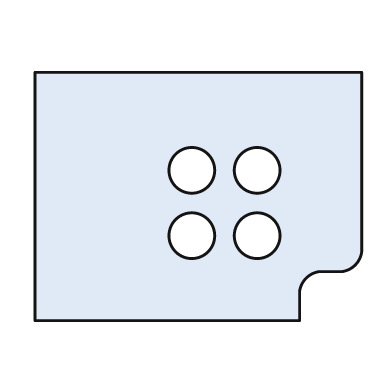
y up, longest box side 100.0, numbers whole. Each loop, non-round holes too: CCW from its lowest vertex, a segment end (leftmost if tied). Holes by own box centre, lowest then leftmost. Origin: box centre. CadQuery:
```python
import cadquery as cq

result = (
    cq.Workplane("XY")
    .moveTo(-50.0, -38.0)
    .lineTo(31.0, -38.0)
    .lineTo(31.0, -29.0)
    .threePointArc((33.0, -25.0), (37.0, -23.0))
    .lineTo(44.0, -23.0)
    .threePointArc((48.0, -21.0), (50.0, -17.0))
    .lineTo(50.0, 38.0)
    .lineTo(-50.0, 38.0)
    .close()
    .moveTo(-2.0, -12.0)
    .circle(7.0)
    .moveTo(18.0, -12.0)
    .circle(7.0)
    .moveTo(-2.0, 8.0)
    .circle(7.0)
    .moveTo(18.0, 8.0)
    .circle(7.0)
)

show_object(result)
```